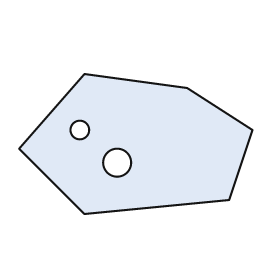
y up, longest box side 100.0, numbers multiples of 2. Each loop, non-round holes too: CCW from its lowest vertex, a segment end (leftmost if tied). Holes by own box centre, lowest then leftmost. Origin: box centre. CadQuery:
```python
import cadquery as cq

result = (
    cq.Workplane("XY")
    .moveTo(-22.0, -30.0)
    .lineTo(40.0, -24.0)
    .lineTo(50.0, 6.0)
    .lineTo(22.0, 24.0)
    .lineTo(-22.0, 30.0)
    .lineTo(-50.0, -2.0)
    .close()
    .moveTo(-8.0, -8.0)
    .circle(6.0)
    .moveTo(-24.0, 6.0)
    .circle(4.0)
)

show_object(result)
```